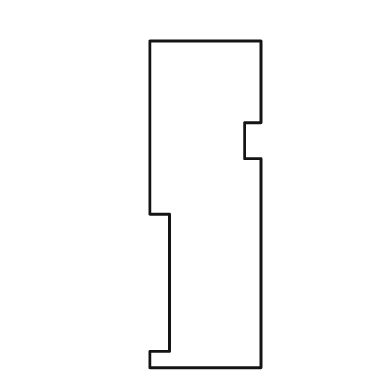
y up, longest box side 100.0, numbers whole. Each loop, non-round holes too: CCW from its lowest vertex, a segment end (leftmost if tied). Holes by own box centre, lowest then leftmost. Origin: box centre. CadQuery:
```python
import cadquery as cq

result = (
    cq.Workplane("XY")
    .moveTo(-17.0, -50.0)
    .lineTo(17.0, -50.0)
    .lineTo(17.0, 14.0)
    .lineTo(12.0, 14.0)
    .lineTo(12.0, 25.0)
    .lineTo(17.0, 25.0)
    .lineTo(17.0, 50.0)
    .lineTo(-17.0, 50.0)
    .lineTo(-17.0, -3.0)
    .lineTo(-11.0, -3.0)
    .lineTo(-11.0, -45.0)
    .lineTo(-17.0, -45.0)
    .close()
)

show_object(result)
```